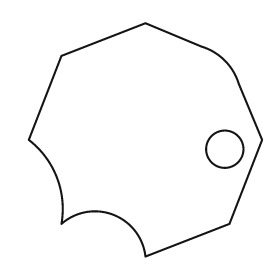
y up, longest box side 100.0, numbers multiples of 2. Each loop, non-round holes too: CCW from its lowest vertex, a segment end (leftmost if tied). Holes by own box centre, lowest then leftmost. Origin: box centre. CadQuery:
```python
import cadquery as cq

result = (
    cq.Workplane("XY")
    .moveTo(0.0, -50.0)
    .lineTo(36.0, -36.0)
    .lineTo(50.0, 0.0)
    .lineTo(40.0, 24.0)
    .threePointArc((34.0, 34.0), (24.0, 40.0))
    .lineTo(0.0, 50.0)
    .lineTo(-36.0, 36.0)
    .lineTo(-50.0, 0.0)
    .threePointArc((-38.0, -16.0), (-36.0, -36.0))
    .threePointArc((-14.0, -32.0), (0.0, -50.0))
    .close()
    .moveTo(34.0, -4.0)
    .circle(8.0)
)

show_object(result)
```